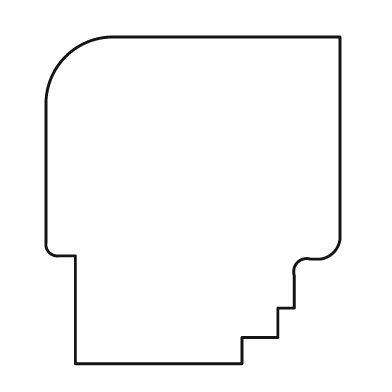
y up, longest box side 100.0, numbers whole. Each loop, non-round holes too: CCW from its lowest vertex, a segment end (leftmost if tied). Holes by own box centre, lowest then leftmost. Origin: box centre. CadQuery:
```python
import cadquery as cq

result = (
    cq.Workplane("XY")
    .moveTo(-36.0, -50.0)
    .lineTo(15.0, -50.0)
    .lineTo(15.0, -42.0)
    .lineTo(26.0, -42.0)
    .lineTo(26.0, -33.0)
    .lineTo(31.0, -33.0)
    .lineTo(31.0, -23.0)
    .threePointArc((32.0, -19.0), (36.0, -18.0))
    .lineTo(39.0, -18.0)
    .threePointArc((43.0, -16.0), (45.0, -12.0))
    .lineTo(45.0, 50.0)
    .lineTo(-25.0, 50.0)
    .threePointArc((-39.0, 44.0), (-45.0, 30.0))
    .lineTo(-45.0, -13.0)
    .threePointArc((-44.0, -16.0), (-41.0, -17.0))
    .lineTo(-36.0, -17.0)
    .close()
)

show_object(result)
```